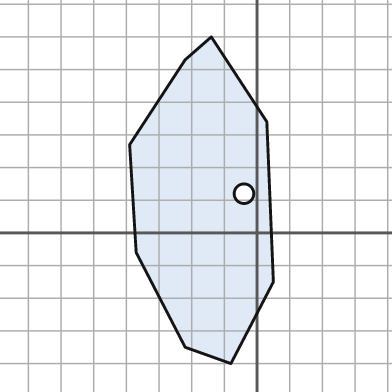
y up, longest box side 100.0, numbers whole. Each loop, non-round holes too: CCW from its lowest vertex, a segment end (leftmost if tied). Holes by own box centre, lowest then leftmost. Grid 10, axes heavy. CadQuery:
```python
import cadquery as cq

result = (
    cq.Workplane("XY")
    .moveTo(-8.0, -40.0)
    .lineTo(5.0, -15.0)
    .lineTo(3.0, 34.0)
    .lineTo(-14.0, 60.0)
    .lineTo(-22.0, 53.0)
    .lineTo(-39.0, 27.0)
    .lineTo(-37.0, -6.0)
    .lineTo(-22.0, -35.0)
    .close()
    .moveTo(-4.0, 12.0)
    .circle(3.0)
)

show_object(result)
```